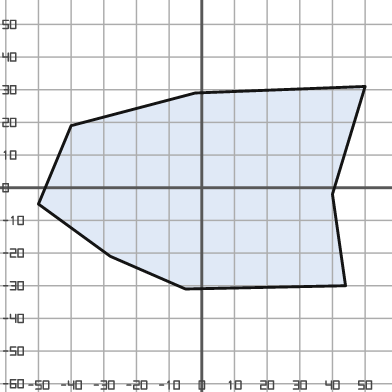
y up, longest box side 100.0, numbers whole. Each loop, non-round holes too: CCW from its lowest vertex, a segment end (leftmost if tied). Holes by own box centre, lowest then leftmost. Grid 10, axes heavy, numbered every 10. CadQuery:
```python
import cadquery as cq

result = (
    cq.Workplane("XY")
    .moveTo(-5.0, -31.0)
    .lineTo(44.0, -30.0)
    .lineTo(40.0, -2.0)
    .lineTo(50.0, 31.0)
    .lineTo(-2.0, 29.0)
    .lineTo(-40.0, 19.0)
    .lineTo(-50.0, -5.0)
    .lineTo(-28.0, -21.0)
    .close()
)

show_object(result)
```